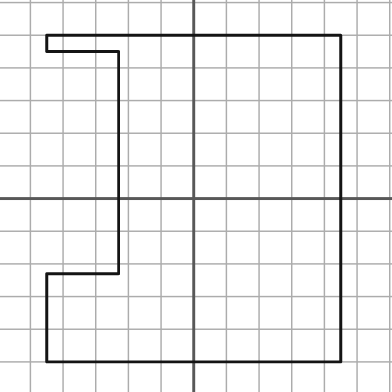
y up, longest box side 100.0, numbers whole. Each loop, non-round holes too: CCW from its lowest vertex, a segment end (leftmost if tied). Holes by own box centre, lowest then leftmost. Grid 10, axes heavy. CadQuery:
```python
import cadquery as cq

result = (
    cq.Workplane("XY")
    .moveTo(-45.0, -50.0)
    .lineTo(45.0, -50.0)
    .lineTo(45.0, 50.0)
    .lineTo(-45.0, 50.0)
    .lineTo(-45.0, 45.0)
    .lineTo(-23.0, 45.0)
    .lineTo(-23.0, -23.0)
    .lineTo(-45.0, -23.0)
    .close()
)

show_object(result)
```